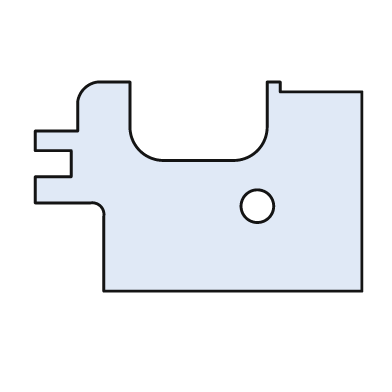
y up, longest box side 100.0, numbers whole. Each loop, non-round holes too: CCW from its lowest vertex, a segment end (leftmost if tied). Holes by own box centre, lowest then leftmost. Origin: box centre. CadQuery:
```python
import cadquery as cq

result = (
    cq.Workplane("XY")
    .moveTo(-29.0, -32.0)
    .lineTo(50.0, -32.0)
    .lineTo(50.0, 29.0)
    .lineTo(25.0, 29.0)
    .lineTo(25.0, 32.0)
    .lineTo(21.0, 32.0)
    .lineTo(21.0, 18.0)
    .threePointArc((18.0, 11.0), (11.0, 8.0))
    .lineTo(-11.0, 8.0)
    .threePointArc((-18.0, 11.0), (-21.0, 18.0))
    .lineTo(-21.0, 32.0)
    .lineTo(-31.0, 32.0)
    .threePointArc((-35.0, 30.0), (-37.0, 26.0))
    .lineTo(-37.0, 17.0)
    .lineTo(-50.0, 17.0)
    .lineTo(-50.0, 11.0)
    .lineTo(-39.0, 11.0)
    .lineTo(-39.0, 3.0)
    .lineTo(-50.0, 3.0)
    .lineTo(-50.0, -5.0)
    .lineTo(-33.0, -5.0)
    .threePointArc((-30.0, -6.0), (-29.0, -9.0))
    .close()
    .moveTo(18.0, -6.0)
    .circle(5.0)
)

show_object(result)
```